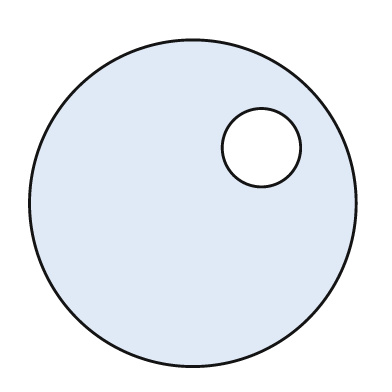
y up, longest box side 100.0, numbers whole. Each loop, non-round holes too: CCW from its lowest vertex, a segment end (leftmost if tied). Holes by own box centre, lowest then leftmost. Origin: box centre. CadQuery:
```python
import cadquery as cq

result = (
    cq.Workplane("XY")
    .moveTo(0.0, 0.0)
    .circle(50.0)
    .moveTo(21.0, 17.0)
    .circle(12.0)
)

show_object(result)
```